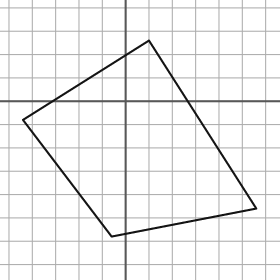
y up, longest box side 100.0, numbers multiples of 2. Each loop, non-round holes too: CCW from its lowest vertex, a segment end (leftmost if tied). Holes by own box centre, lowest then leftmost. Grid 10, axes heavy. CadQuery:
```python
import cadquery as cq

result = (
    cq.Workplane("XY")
    .moveTo(-6.0, -58.0)
    .lineTo(56.0, -46.0)
    .lineTo(10.0, 26.0)
    .lineTo(-44.0, -8.0)
    .close()
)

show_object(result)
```